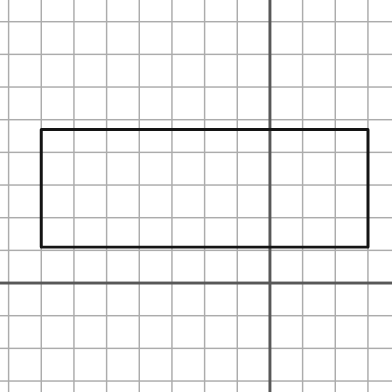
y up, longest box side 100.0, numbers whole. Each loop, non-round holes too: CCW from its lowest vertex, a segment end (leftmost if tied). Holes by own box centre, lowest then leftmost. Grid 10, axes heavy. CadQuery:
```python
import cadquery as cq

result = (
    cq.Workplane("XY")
    .moveTo(-70.0, 11.0)
    .lineTo(30.0, 11.0)
    .lineTo(30.0, 47.0)
    .lineTo(-70.0, 47.0)
    .close()
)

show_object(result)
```